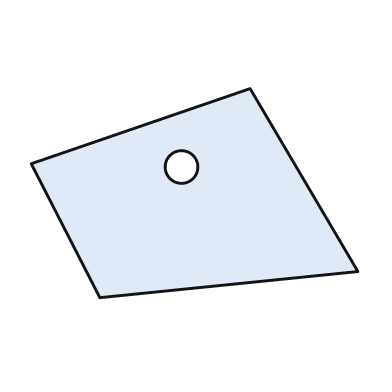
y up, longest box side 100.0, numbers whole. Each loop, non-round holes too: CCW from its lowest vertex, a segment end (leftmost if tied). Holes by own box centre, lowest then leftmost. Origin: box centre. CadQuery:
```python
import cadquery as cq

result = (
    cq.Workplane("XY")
    .moveTo(-29.0, -32.0)
    .lineTo(50.0, -24.0)
    .lineTo(17.0, 32.0)
    .lineTo(-50.0, 9.0)
    .close()
    .moveTo(-4.0, 8.0)
    .circle(5.0)
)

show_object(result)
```